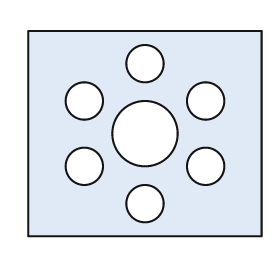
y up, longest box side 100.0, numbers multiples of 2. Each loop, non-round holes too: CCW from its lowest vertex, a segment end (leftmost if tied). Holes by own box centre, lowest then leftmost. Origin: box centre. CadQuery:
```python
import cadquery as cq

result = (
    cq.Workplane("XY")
    .moveTo(-50.0, -44.0)
    .lineTo(50.0, -44.0)
    .lineTo(50.0, 44.0)
    .lineTo(-50.0, 44.0)
    .close()
    .moveTo(0.0, -30.0)
    .circle(8.0)
    .moveTo(-26.0, -14.0)
    .circle(8.0)
    .moveTo(26.0, -14.0)
    .circle(8.0)
    .moveTo(0.0, 0.0)
    .circle(14.0)
    .moveTo(-26.0, 14.0)
    .circle(8.0)
    .moveTo(26.0, 14.0)
    .circle(8.0)
    .moveTo(0.0, 30.0)
    .circle(8.0)
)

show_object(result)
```